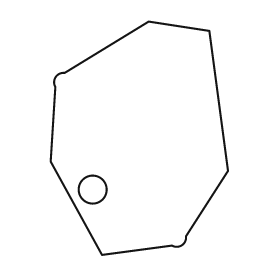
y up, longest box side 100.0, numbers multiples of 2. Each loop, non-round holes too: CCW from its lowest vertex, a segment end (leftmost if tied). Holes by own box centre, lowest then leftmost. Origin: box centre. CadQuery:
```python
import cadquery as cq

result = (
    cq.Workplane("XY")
    .moveTo(-16.0, -50.0)
    .lineTo(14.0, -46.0)
    .threePointArc((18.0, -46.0), (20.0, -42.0))
    .lineTo(38.0, -14.0)
    .lineTo(30.0, 46.0)
    .lineTo(4.0, 50.0)
    .lineTo(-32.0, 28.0)
    .threePointArc((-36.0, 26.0), (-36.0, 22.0))
    .lineTo(-38.0, -10.0)
    .close()
    .moveTo(-20.0, -22.0)
    .circle(6.0)
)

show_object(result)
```